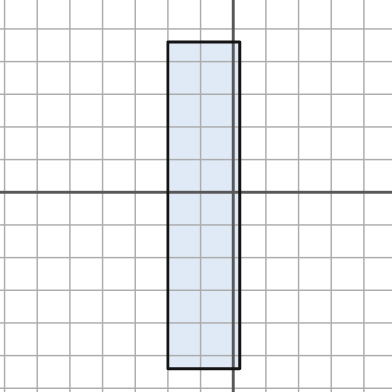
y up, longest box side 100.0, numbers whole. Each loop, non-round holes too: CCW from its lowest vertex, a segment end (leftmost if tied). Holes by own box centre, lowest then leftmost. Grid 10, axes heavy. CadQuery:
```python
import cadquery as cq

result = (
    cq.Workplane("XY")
    .moveTo(-20.0, -54.0)
    .lineTo(2.0, -54.0)
    .lineTo(2.0, 46.0)
    .lineTo(-20.0, 46.0)
    .close()
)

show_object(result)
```